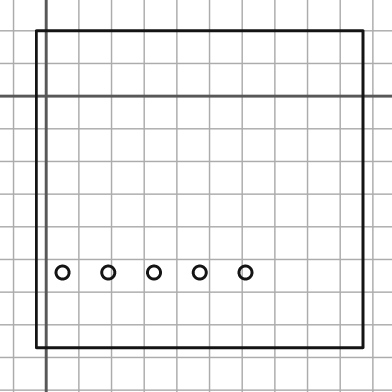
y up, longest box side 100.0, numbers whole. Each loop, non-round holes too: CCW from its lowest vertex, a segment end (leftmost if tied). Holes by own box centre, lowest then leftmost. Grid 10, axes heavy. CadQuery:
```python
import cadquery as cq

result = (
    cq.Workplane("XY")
    .moveTo(-3.0, -77.0)
    .lineTo(97.0, -77.0)
    .lineTo(97.0, 20.0)
    .lineTo(-3.0, 20.0)
    .close()
    .moveTo(5.0, -54.0)
    .circle(2.0)
    .moveTo(19.0, -54.0)
    .circle(2.0)
    .moveTo(33.0, -54.0)
    .circle(2.0)
    .moveTo(47.0, -54.0)
    .circle(2.0)
    .moveTo(61.0, -54.0)
    .circle(2.0)
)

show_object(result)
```